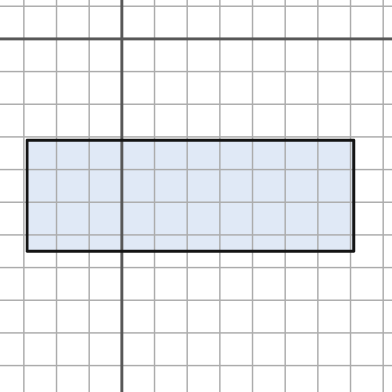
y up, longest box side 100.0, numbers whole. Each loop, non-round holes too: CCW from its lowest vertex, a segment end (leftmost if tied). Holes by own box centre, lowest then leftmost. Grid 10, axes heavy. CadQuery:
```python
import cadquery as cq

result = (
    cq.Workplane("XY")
    .moveTo(-29.0, -65.0)
    .lineTo(71.0, -65.0)
    .lineTo(71.0, -31.0)
    .lineTo(-29.0, -31.0)
    .close()
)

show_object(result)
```